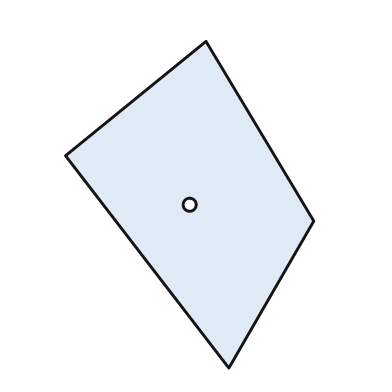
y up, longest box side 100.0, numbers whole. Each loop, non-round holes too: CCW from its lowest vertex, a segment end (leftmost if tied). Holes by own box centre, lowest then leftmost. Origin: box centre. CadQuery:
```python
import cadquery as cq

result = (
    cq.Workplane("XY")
    .moveTo(12.0, -50.0)
    .lineTo(38.0, -5.0)
    .lineTo(5.0, 50.0)
    .lineTo(-38.0, 15.0)
    .close()
    .moveTo(0.0, 0.0)
    .circle(2.0)
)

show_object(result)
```